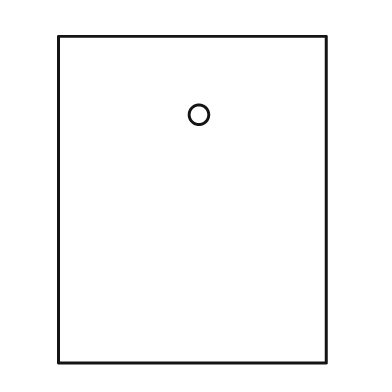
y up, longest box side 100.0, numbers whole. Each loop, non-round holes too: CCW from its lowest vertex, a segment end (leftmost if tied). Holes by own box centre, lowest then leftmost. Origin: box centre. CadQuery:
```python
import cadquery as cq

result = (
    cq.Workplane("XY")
    .moveTo(-41.0, -50.0)
    .lineTo(41.0, -50.0)
    .lineTo(41.0, 50.0)
    .lineTo(-41.0, 50.0)
    .close()
    .moveTo(2.0, 26.0)
    .circle(3.0)
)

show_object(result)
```